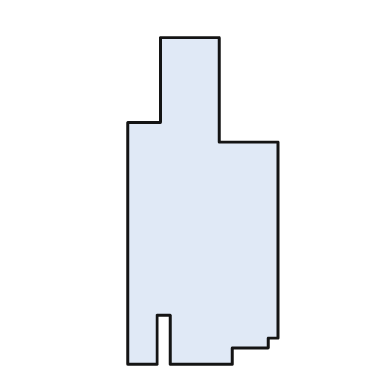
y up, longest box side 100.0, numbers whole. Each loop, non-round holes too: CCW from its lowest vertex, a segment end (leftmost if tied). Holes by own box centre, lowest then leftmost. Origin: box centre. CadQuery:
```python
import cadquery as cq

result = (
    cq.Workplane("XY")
    .moveTo(-23.0, -50.0)
    .lineTo(-14.0, -50.0)
    .lineTo(-14.0, -35.0)
    .lineTo(-10.0, -35.0)
    .lineTo(-10.0, -50.0)
    .lineTo(9.0, -50.0)
    .lineTo(9.0, -45.0)
    .lineTo(20.0, -45.0)
    .lineTo(20.0, -42.0)
    .lineTo(23.0, -42.0)
    .lineTo(23.0, 18.0)
    .lineTo(5.0, 18.0)
    .lineTo(5.0, 50.0)
    .lineTo(-13.0, 50.0)
    .lineTo(-13.0, 24.0)
    .lineTo(-23.0, 24.0)
    .close()
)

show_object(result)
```